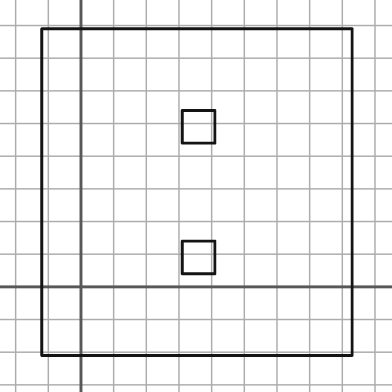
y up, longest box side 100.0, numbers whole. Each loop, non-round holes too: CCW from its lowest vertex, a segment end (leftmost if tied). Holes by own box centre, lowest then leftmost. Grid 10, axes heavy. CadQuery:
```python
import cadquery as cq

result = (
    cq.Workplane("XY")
    .moveTo(-12.0, -21.0)
    .lineTo(83.0, -21.0)
    .lineTo(83.0, 79.0)
    .lineTo(-12.0, 79.0)
    .close()
    .moveTo(31.0, 4.0)
    .lineTo(41.0, 4.0)
    .lineTo(41.0, 14.0)
    .lineTo(31.0, 14.0)
    .close()
    .moveTo(31.0, 44.0)
    .lineTo(41.0, 44.0)
    .lineTo(41.0, 54.0)
    .lineTo(31.0, 54.0)
    .close()
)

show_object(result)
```